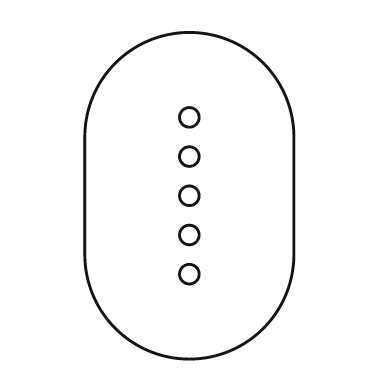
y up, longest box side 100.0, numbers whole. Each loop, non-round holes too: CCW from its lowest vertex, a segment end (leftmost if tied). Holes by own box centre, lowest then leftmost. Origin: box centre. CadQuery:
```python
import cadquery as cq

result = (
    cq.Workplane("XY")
    .moveTo(-32.0, -18.0)
    .threePointArc((0.0, -50.0), (32.0, -18.0))
    .lineTo(32.0, 18.0)
    .threePointArc((0.0, 50.0), (-32.0, 18.0))
    .close()
    .moveTo(0.0, -24.0)
    .circle(3.0)
    .moveTo(0.0, -12.0)
    .circle(3.0)
    .moveTo(0.0, 0.0)
    .circle(3.0)
    .moveTo(0.0, 12.0)
    .circle(3.0)
    .moveTo(0.0, 24.0)
    .circle(3.0)
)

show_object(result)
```